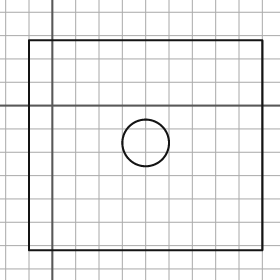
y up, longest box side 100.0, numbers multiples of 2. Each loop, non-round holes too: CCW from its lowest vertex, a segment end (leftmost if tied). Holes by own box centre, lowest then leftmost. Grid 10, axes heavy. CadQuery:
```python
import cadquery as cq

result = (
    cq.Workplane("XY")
    .moveTo(-10.0, -62.0)
    .lineTo(90.0, -62.0)
    .lineTo(90.0, 28.0)
    .lineTo(-10.0, 28.0)
    .close()
    .moveTo(40.0, -16.0)
    .circle(10.0)
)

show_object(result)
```